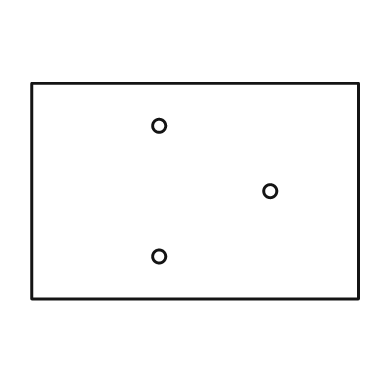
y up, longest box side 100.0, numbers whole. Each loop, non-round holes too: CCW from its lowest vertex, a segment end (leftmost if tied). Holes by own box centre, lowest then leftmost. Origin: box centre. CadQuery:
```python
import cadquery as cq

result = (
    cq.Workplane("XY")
    .moveTo(-50.0, -33.0)
    .lineTo(50.0, -33.0)
    .lineTo(50.0, 33.0)
    .lineTo(-50.0, 33.0)
    .close()
    .moveTo(-11.0, -20.0)
    .circle(2.0)
    .moveTo(23.0, 0.0)
    .circle(2.0)
    .moveTo(-11.0, 20.0)
    .circle(2.0)
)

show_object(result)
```